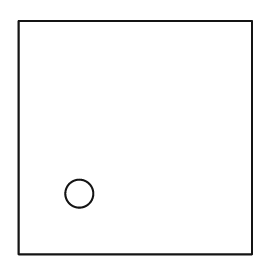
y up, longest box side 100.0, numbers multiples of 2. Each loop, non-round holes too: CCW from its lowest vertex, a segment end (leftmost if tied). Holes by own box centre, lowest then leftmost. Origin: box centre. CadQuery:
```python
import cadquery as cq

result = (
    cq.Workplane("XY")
    .moveTo(-50.0, -50.0)
    .lineTo(50.0, -50.0)
    .lineTo(50.0, 50.0)
    .lineTo(-50.0, 50.0)
    .close()
    .moveTo(-24.0, -24.0)
    .circle(6.0)
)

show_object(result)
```